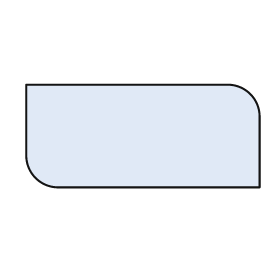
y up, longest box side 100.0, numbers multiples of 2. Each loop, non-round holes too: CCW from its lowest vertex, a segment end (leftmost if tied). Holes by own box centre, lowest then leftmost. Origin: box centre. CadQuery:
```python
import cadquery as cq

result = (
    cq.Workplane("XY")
    .moveTo(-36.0, -22.0)
    .lineTo(50.0, -22.0)
    .lineTo(50.0, 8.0)
    .threePointArc((46.0, 18.0), (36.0, 22.0))
    .lineTo(-50.0, 22.0)
    .lineTo(-50.0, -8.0)
    .threePointArc((-46.0, -18.0), (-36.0, -22.0))
    .close()
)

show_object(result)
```